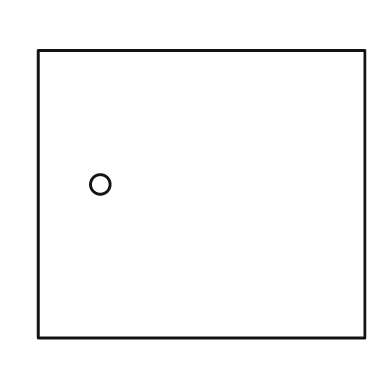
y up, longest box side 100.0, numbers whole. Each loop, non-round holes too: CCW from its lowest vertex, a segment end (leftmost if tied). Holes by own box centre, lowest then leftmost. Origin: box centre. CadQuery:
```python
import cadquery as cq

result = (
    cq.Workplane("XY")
    .moveTo(-50.0, -44.0)
    .lineTo(50.0, -44.0)
    .lineTo(50.0, 44.0)
    .lineTo(-50.0, 44.0)
    .close()
    .moveTo(-31.0, 3.0)
    .circle(3.0)
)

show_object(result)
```